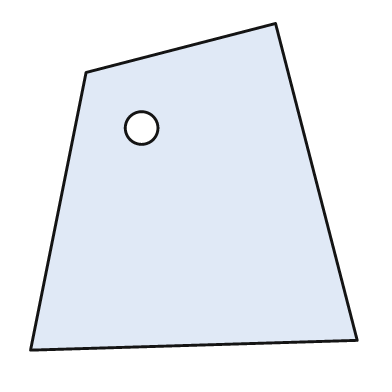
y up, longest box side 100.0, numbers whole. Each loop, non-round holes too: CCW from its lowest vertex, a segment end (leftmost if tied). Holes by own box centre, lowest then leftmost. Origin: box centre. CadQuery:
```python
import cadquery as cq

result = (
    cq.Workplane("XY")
    .moveTo(-50.0, -50.0)
    .lineTo(50.0, -47.0)
    .lineTo(25.0, 50.0)
    .lineTo(-33.0, 35.0)
    .close()
    .moveTo(-16.0, 18.0)
    .circle(5.0)
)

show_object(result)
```